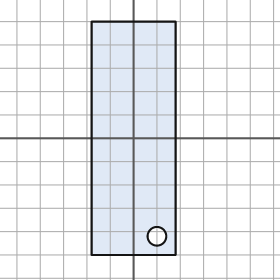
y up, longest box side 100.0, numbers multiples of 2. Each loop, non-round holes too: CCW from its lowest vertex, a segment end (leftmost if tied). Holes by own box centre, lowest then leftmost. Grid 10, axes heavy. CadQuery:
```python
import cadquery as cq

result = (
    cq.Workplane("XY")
    .moveTo(-18.0, -50.0)
    .lineTo(18.0, -50.0)
    .lineTo(18.0, 50.0)
    .lineTo(-18.0, 50.0)
    .close()
    .moveTo(10.0, -42.0)
    .circle(4.0)
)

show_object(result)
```